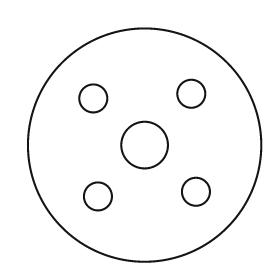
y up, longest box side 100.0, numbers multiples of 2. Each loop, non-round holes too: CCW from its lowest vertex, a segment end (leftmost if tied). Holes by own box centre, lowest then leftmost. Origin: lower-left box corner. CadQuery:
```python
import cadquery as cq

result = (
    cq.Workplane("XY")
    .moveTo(50.0, 50.0)
    .circle(50.0)
    .moveTo(30.0, 28.0)
    .circle(6.0)
    .moveTo(72.0, 30.0)
    .circle(6.0)
    .moveTo(50.0, 50.0)
    .circle(10.0)
    .moveTo(28.0, 70.0)
    .circle(6.0)
    .moveTo(70.0, 72.0)
    .circle(6.0)
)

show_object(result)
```